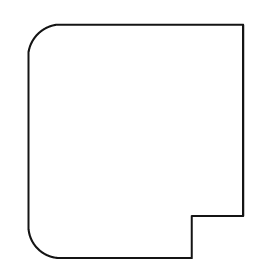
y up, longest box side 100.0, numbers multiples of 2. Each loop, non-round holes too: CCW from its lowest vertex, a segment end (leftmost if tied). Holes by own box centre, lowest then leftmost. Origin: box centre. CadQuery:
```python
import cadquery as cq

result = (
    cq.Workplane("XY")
    .moveTo(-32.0, -50.0)
    .lineTo(24.0, -50.0)
    .lineTo(24.0, -32.0)
    .lineTo(46.0, -32.0)
    .lineTo(46.0, 50.0)
    .lineTo(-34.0, 50.0)
    .threePointArc((-42.0, 46.0), (-46.0, 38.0))
    .lineTo(-46.0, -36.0)
    .threePointArc((-42.0, -46.0), (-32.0, -50.0))
    .close()
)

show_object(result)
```